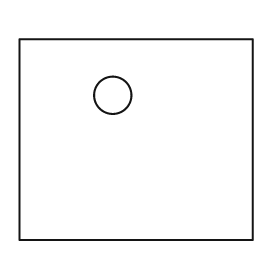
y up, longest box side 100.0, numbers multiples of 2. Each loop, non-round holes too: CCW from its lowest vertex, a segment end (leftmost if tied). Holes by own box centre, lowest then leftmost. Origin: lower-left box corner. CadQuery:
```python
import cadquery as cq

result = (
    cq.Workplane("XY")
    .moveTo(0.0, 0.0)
    .lineTo(100.0, 0.0)
    .lineTo(100.0, 86.0)
    .lineTo(0.0, 86.0)
    .close()
    .moveTo(40.0, 62.0)
    .circle(8.0)
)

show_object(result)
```